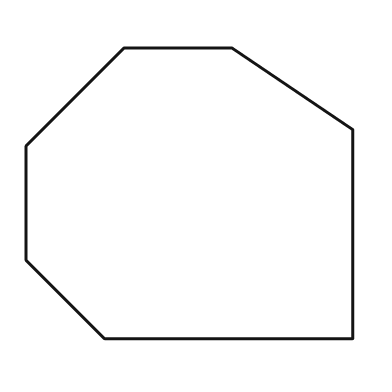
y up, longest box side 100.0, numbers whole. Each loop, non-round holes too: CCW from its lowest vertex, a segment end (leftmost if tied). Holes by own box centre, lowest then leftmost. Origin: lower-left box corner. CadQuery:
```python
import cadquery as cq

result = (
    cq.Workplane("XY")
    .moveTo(24.0, 0.0)
    .lineTo(100.0, 0.0)
    .lineTo(100.0, 64.0)
    .lineTo(63.0, 89.0)
    .lineTo(30.0, 89.0)
    .lineTo(0.0, 59.0)
    .lineTo(0.0, 24.0)
    .close()
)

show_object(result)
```